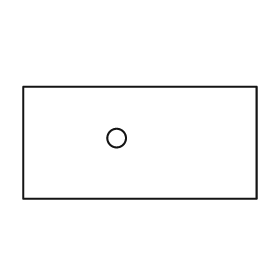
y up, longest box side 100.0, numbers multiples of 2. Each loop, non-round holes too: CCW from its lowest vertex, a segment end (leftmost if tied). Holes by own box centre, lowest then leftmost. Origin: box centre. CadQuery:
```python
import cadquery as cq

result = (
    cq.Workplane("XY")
    .moveTo(-50.0, -24.0)
    .lineTo(50.0, -24.0)
    .lineTo(50.0, 24.0)
    .lineTo(-50.0, 24.0)
    .close()
    .moveTo(-10.0, 2.0)
    .circle(4.0)
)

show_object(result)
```